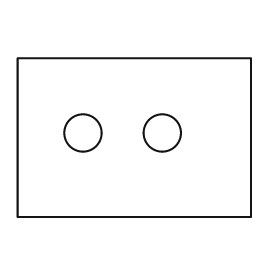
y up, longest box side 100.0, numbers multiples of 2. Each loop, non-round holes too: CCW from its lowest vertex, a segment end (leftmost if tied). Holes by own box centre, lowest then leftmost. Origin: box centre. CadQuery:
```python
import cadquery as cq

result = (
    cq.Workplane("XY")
    .moveTo(-50.0, -34.0)
    .lineTo(50.0, -34.0)
    .lineTo(50.0, 34.0)
    .lineTo(-50.0, 34.0)
    .close()
    .moveTo(-22.0, 2.0)
    .circle(8.0)
    .moveTo(12.0, 2.0)
    .circle(8.0)
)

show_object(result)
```